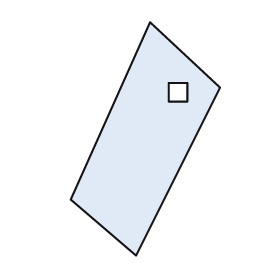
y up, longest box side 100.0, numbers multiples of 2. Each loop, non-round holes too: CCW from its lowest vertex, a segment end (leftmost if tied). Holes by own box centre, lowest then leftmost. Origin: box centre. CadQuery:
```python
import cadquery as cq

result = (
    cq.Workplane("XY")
    .moveTo(-4.0, -50.0)
    .lineTo(32.0, 22.0)
    .lineTo(2.0, 50.0)
    .lineTo(-32.0, -26.0)
    .close()
    .moveTo(10.0, 16.0)
    .lineTo(18.0, 16.0)
    .lineTo(18.0, 24.0)
    .lineTo(10.0, 24.0)
    .close()
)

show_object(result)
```